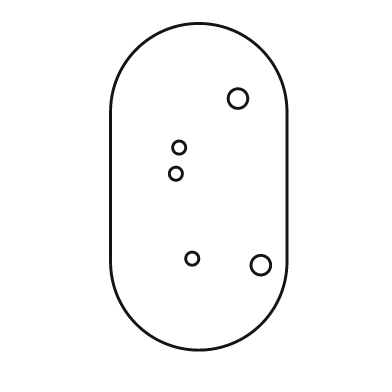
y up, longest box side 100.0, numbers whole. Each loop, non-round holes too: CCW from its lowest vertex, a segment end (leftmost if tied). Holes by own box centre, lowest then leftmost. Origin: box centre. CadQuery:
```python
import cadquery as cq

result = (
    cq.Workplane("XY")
    .moveTo(-27.0, -23.0)
    .threePointArc((0.0, -50.0), (27.0, -23.0))
    .lineTo(27.0, 23.0)
    .threePointArc((0.0, 50.0), (-27.0, 23.0))
    .close()
    .moveTo(19.0, -24.0)
    .circle(3.0)
    .moveTo(-2.0, -22.0)
    .circle(2.0)
    .moveTo(-7.0, 4.0)
    .circle(2.0)
    .moveTo(-6.0, 12.0)
    .circle(2.0)
    .moveTo(12.0, 27.0)
    .circle(3.0)
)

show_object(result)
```